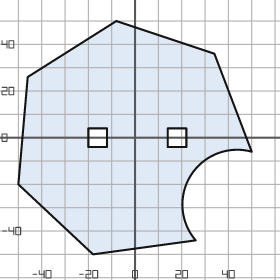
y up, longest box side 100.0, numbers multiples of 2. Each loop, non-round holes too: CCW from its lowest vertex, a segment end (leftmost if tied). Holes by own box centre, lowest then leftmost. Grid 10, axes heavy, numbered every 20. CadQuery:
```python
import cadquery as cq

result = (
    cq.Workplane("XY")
    .moveTo(-18.0, -50.0)
    .lineTo(26.0, -44.0)
    .threePointArc((24.0, -16.0), (50.0, -6.0))
    .lineTo(34.0, 36.0)
    .lineTo(-8.0, 50.0)
    .lineTo(-46.0, 26.0)
    .lineTo(-50.0, -20.0)
    .close()
    .moveTo(-20.0, -4.0)
    .lineTo(-12.0, -4.0)
    .lineTo(-12.0, 4.0)
    .lineTo(-20.0, 4.0)
    .close()
    .moveTo(14.0, -4.0)
    .lineTo(22.0, -4.0)
    .lineTo(22.0, 4.0)
    .lineTo(14.0, 4.0)
    .close()
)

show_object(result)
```